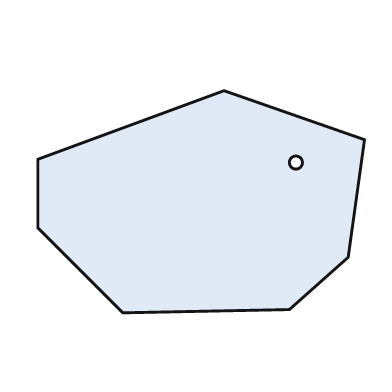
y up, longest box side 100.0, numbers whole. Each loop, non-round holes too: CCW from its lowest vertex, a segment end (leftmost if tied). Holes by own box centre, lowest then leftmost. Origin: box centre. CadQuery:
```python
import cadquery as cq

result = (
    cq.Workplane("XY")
    .moveTo(-24.0, -34.0)
    .lineTo(27.0, -33.0)
    .lineTo(45.0, -17.0)
    .lineTo(50.0, 19.0)
    .lineTo(7.0, 34.0)
    .lineTo(-50.0, 13.0)
    .lineTo(-50.0, -8.0)
    .close()
    .moveTo(29.0, 12.0)
    .circle(2.0)
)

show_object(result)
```